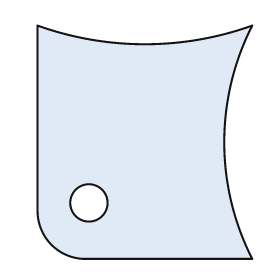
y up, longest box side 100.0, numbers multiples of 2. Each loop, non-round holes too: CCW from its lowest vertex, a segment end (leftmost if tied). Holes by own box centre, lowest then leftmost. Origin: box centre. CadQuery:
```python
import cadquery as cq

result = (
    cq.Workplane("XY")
    .moveTo(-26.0, -50.0)
    .lineTo(46.0, -50.0)
    .threePointArc((34.0, 0.0), (46.0, 50.0))
    .threePointArc((0.0, 42.0), (-46.0, 50.0))
    .lineTo(-46.0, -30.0)
    .threePointArc((-40.0, -44.0), (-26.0, -50.0))
    .close()
    .moveTo(-24.0, -26.0)
    .circle(8.0)
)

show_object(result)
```